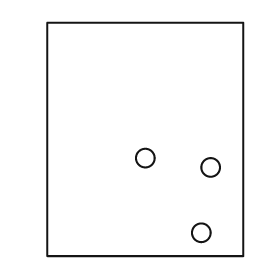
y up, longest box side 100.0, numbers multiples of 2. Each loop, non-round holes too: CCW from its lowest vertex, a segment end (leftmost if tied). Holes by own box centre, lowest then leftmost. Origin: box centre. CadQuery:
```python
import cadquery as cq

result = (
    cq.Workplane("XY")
    .moveTo(-42.0, -50.0)
    .lineTo(42.0, -50.0)
    .lineTo(42.0, 50.0)
    .lineTo(-42.0, 50.0)
    .close()
    .moveTo(24.0, -40.0)
    .circle(4.0)
    .moveTo(28.0, -12.0)
    .circle(4.0)
    .moveTo(0.0, -8.0)
    .circle(4.0)
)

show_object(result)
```